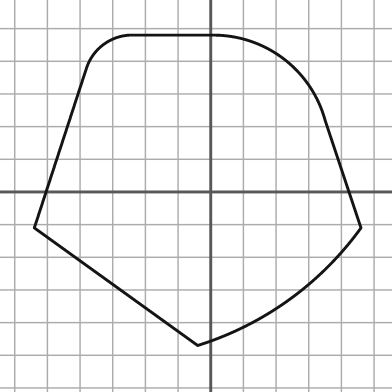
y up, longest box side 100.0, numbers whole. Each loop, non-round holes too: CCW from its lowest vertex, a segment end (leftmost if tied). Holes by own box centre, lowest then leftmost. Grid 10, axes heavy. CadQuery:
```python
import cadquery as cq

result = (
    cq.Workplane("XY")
    .moveTo(-4.0, -47.0)
    .threePointArc((24.0, -33.0), (46.0, -11.0))
    .lineTo(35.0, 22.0)
    .threePointArc((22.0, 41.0), (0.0, 48.0))
    .lineTo(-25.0, 48.0)
    .threePointArc((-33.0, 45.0), (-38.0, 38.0))
    .lineTo(-54.0, -11.0)
    .close()
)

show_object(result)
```